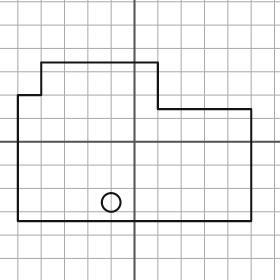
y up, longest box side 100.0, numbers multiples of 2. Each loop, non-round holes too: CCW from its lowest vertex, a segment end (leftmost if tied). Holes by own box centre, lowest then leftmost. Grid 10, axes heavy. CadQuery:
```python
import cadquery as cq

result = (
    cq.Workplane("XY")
    .moveTo(-50.0, -34.0)
    .lineTo(50.0, -34.0)
    .lineTo(50.0, 14.0)
    .lineTo(10.0, 14.0)
    .lineTo(10.0, 34.0)
    .lineTo(-40.0, 34.0)
    .lineTo(-40.0, 20.0)
    .lineTo(-50.0, 20.0)
    .close()
    .moveTo(-10.0, -26.0)
    .circle(4.0)
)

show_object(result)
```